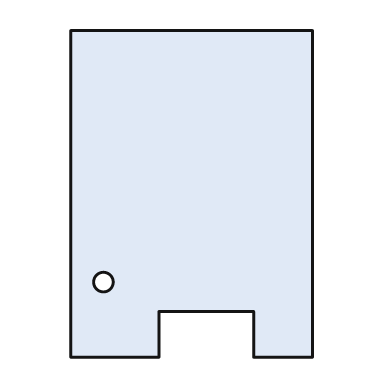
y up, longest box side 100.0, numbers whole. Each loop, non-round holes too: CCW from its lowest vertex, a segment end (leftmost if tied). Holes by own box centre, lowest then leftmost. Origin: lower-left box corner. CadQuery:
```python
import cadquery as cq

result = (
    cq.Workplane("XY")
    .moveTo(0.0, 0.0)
    .lineTo(27.0, 0.0)
    .lineTo(27.0, 14.0)
    .lineTo(56.0, 14.0)
    .lineTo(56.0, 0.0)
    .lineTo(74.0, 0.0)
    .lineTo(74.0, 100.0)
    .lineTo(0.0, 100.0)
    .close()
    .moveTo(10.0, 23.0)
    .circle(3.0)
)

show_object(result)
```